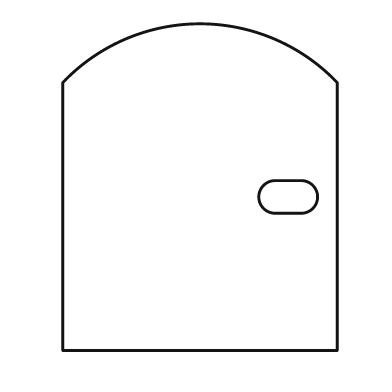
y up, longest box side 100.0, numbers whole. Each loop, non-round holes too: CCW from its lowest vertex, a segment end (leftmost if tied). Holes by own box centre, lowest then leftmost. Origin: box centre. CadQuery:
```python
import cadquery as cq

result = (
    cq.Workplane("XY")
    .moveTo(-42.0, -50.0)
    .lineTo(42.0, -50.0)
    .lineTo(42.0, 32.0)
    .threePointArc((0.0, 50.0), (-42.0, 32.0))
    .close()
    .moveTo(23.0, -8.0)
    .lineTo(31.0, -8.0)
    .threePointArc((36.0, -3.0), (31.0, 2.0))
    .lineTo(23.0, 2.0)
    .threePointArc((18.0, -3.0), (23.0, -8.0))
    .close()
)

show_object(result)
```